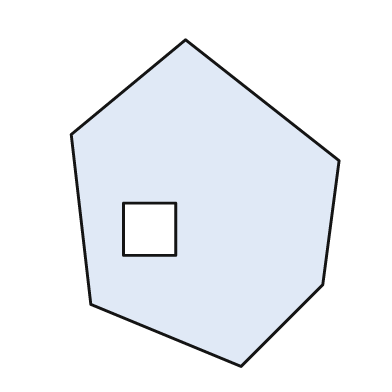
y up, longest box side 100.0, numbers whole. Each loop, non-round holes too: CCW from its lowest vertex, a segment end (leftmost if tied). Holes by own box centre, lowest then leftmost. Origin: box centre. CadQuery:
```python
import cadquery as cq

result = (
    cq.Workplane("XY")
    .moveTo(11.0, -50.0)
    .lineTo(36.0, -25.0)
    .lineTo(41.0, 13.0)
    .lineTo(-6.0, 50.0)
    .lineTo(-41.0, 21.0)
    .lineTo(-35.0, -31.0)
    .close()
    .moveTo(-25.0, -16.0)
    .lineTo(-9.0, -16.0)
    .lineTo(-9.0, 0.0)
    .lineTo(-25.0, 0.0)
    .close()
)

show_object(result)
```